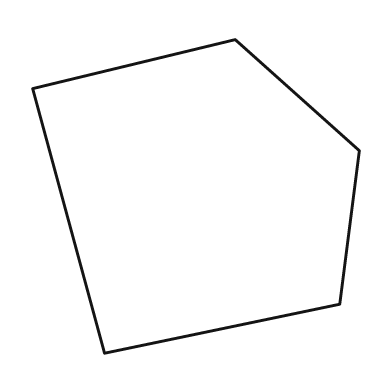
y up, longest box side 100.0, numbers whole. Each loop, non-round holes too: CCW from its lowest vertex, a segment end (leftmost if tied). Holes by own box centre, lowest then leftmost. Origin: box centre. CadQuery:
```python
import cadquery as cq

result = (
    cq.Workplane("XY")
    .moveTo(-28.0, -48.0)
    .lineTo(44.0, -33.0)
    .lineTo(50.0, 14.0)
    .lineTo(12.0, 48.0)
    .lineTo(-50.0, 33.0)
    .close()
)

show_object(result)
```